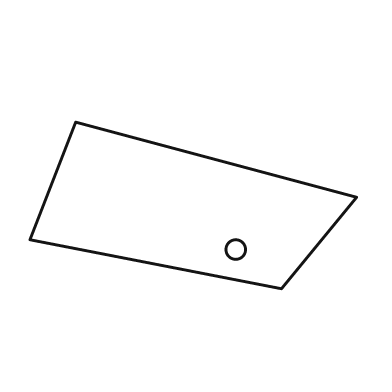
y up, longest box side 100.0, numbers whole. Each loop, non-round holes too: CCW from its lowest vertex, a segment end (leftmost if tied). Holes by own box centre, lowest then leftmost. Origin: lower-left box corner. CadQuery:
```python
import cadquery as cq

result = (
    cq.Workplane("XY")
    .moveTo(77.0, 0.0)
    .lineTo(100.0, 28.0)
    .lineTo(14.0, 51.0)
    .lineTo(0.0, 15.0)
    .close()
    .moveTo(63.0, 12.0)
    .circle(3.0)
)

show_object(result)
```